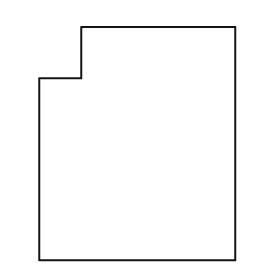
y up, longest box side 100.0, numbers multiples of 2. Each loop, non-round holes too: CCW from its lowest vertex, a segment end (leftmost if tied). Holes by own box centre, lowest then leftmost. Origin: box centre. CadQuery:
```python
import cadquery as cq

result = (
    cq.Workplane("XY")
    .moveTo(-42.0, -50.0)
    .lineTo(42.0, -50.0)
    .lineTo(42.0, 50.0)
    .lineTo(-24.0, 50.0)
    .lineTo(-24.0, 28.0)
    .lineTo(-42.0, 28.0)
    .close()
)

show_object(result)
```